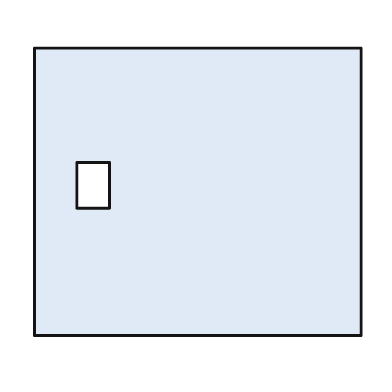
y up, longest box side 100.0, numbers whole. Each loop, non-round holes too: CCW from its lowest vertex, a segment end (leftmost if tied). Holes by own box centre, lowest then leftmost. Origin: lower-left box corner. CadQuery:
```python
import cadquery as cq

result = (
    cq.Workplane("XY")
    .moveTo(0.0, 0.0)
    .lineTo(100.0, 0.0)
    .lineTo(100.0, 88.0)
    .lineTo(0.0, 88.0)
    .close()
    .moveTo(13.0, 39.0)
    .lineTo(23.0, 39.0)
    .lineTo(23.0, 53.0)
    .lineTo(13.0, 53.0)
    .close()
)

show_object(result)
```